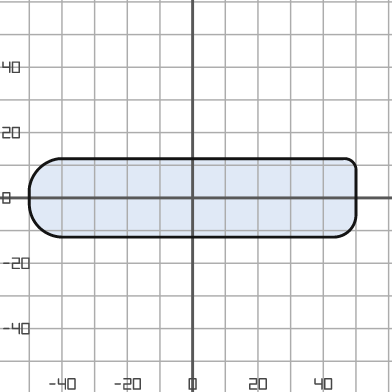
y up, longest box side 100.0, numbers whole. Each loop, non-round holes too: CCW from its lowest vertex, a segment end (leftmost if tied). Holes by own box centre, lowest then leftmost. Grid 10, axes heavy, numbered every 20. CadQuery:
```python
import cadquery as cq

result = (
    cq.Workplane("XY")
    .moveTo(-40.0, -12.0)
    .lineTo(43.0, -12.0)
    .threePointArc((48.0, -10.0), (50.0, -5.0))
    .lineTo(50.0, 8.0)
    .threePointArc((49.0, 11.0), (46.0, 12.0))
    .lineTo(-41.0, 12.0)
    .threePointArc((-47.0, 9.0), (-50.0, 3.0))
    .lineTo(-50.0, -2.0)
    .threePointArc((-47.0, -9.0), (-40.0, -12.0))
    .close()
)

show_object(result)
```